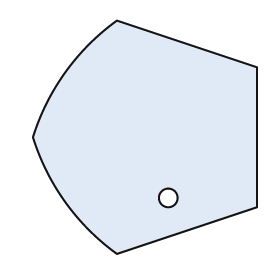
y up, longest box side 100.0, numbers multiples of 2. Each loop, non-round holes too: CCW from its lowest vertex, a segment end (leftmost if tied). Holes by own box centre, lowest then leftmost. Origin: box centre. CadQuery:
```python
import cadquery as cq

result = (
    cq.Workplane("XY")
    .moveTo(-12.0, -50.0)
    .lineTo(48.0, -30.0)
    .lineTo(48.0, 30.0)
    .lineTo(-12.0, 50.0)
    .threePointArc((-34.0, 28.0), (-48.0, 0.0))
    .threePointArc((-34.0, -28.0), (-12.0, -50.0))
    .close()
    .moveTo(10.0, -26.0)
    .circle(4.0)
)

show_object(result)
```